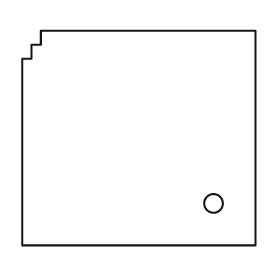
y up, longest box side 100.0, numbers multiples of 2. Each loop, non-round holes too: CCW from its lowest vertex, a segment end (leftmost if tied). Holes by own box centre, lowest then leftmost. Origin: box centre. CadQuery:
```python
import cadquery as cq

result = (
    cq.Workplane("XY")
    .moveTo(-50.0, -46.0)
    .lineTo(50.0, -46.0)
    .lineTo(50.0, 46.0)
    .lineTo(-42.0, 46.0)
    .lineTo(-42.0, 40.0)
    .lineTo(-46.0, 40.0)
    .lineTo(-46.0, 34.0)
    .lineTo(-50.0, 34.0)
    .close()
    .moveTo(32.0, -28.0)
    .circle(4.0)
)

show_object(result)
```